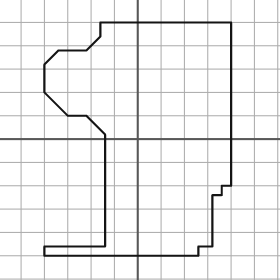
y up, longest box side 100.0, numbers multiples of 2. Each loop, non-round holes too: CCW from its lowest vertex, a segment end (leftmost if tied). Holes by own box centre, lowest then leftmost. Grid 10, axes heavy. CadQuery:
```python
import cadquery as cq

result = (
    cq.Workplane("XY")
    .moveTo(-40.0, -50.0)
    .lineTo(26.0, -50.0)
    .lineTo(26.0, -46.0)
    .lineTo(32.0, -46.0)
    .lineTo(32.0, -24.0)
    .lineTo(36.0, -24.0)
    .lineTo(36.0, -20.0)
    .lineTo(40.0, -20.0)
    .lineTo(40.0, 50.0)
    .lineTo(-16.0, 50.0)
    .lineTo(-16.0, 44.0)
    .lineTo(-22.0, 38.0)
    .lineTo(-34.0, 38.0)
    .lineTo(-40.0, 32.0)
    .lineTo(-40.0, 20.0)
    .lineTo(-30.0, 10.0)
    .lineTo(-22.0, 10.0)
    .lineTo(-14.0, 2.0)
    .lineTo(-14.0, -46.0)
    .lineTo(-40.0, -46.0)
    .close()
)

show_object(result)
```